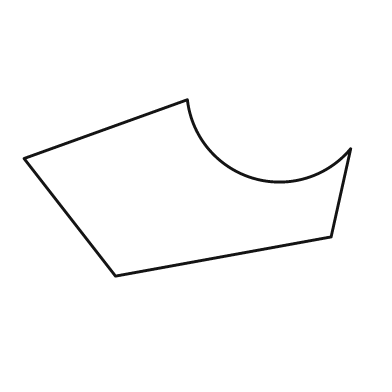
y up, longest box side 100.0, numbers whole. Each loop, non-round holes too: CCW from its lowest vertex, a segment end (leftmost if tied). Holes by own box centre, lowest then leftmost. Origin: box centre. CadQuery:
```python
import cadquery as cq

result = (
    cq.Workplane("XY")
    .moveTo(-22.0, -27.0)
    .lineTo(44.0, -15.0)
    .lineTo(50.0, 12.0)
    .threePointArc((20.0, 3.0), (0.0, 27.0))
    .lineTo(-50.0, 9.0)
    .close()
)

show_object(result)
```